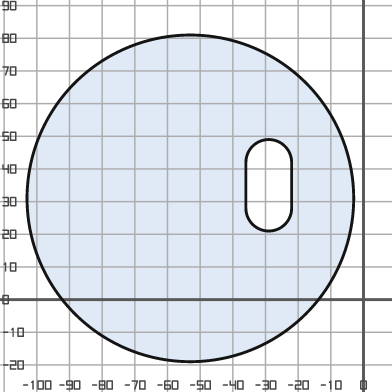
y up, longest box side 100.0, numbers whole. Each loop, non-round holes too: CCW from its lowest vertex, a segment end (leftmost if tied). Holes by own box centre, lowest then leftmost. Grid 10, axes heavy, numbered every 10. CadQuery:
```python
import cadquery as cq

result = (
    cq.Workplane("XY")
    .moveTo(-53.0, 31.0)
    .circle(50.0)
    .moveTo(-36.0, 28.0)
    .threePointArc((-29.0, 21.0), (-22.0, 28.0))
    .lineTo(-22.0, 42.0)
    .threePointArc((-29.0, 49.0), (-36.0, 42.0))
    .close()
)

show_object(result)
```